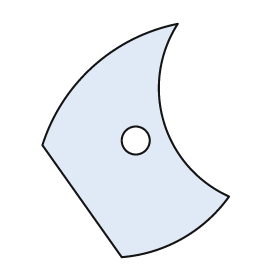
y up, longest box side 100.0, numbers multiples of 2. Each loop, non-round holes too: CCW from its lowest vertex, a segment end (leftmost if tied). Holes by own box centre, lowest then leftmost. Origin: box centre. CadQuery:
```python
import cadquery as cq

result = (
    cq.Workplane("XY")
    .moveTo(-6.0, -50.0)
    .threePointArc((20.0, -42.0), (40.0, -24.0))
    .threePointArc((12.0, 8.0), (18.0, 50.0))
    .threePointArc((-18.0, 32.0), (-40.0, -2.0))
    .close()
    .moveTo(0.0, 0.0)
    .circle(6.0)
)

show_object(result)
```